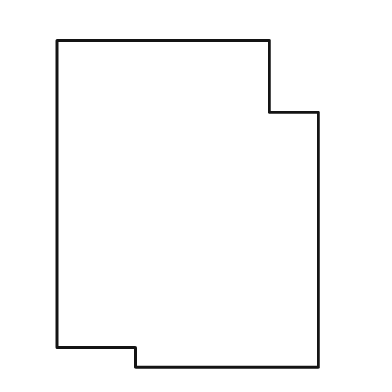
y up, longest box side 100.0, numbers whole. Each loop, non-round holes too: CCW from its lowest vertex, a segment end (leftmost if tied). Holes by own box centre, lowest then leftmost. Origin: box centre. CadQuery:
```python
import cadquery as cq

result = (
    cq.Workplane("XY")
    .moveTo(-16.0, -50.0)
    .lineTo(40.0, -50.0)
    .lineTo(40.0, 28.0)
    .lineTo(25.0, 28.0)
    .lineTo(25.0, 50.0)
    .lineTo(-40.0, 50.0)
    .lineTo(-40.0, -44.0)
    .lineTo(-16.0, -44.0)
    .close()
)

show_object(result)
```